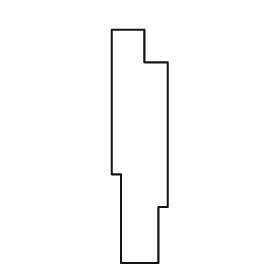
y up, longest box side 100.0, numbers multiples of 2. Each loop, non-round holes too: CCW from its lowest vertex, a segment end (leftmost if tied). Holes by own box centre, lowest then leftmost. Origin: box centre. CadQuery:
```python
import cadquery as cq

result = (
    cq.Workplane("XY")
    .moveTo(-8.0, -50.0)
    .lineTo(8.0, -50.0)
    .lineTo(8.0, -26.0)
    .lineTo(12.0, -26.0)
    .lineTo(12.0, 36.0)
    .lineTo(2.0, 36.0)
    .lineTo(2.0, 50.0)
    .lineTo(-12.0, 50.0)
    .lineTo(-12.0, -12.0)
    .lineTo(-8.0, -12.0)
    .close()
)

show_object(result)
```